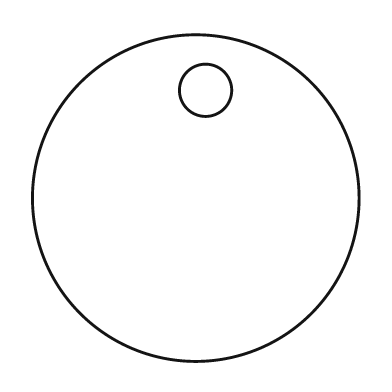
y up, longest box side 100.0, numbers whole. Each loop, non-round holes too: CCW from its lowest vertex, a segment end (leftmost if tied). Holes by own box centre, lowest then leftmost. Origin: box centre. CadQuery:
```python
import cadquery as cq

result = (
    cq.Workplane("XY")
    .moveTo(0.0, 0.0)
    .circle(50.0)
    .moveTo(3.0, 33.0)
    .circle(8.0)
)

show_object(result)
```